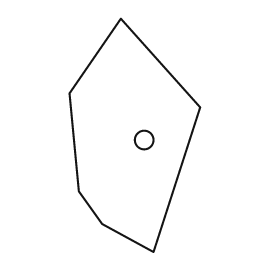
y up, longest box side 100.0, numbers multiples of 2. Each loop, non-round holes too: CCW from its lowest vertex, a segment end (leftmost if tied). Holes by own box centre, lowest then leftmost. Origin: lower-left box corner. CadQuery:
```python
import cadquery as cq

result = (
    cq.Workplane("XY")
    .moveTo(36.0, 0.0)
    .lineTo(56.0, 62.0)
    .lineTo(22.0, 100.0)
    .lineTo(0.0, 68.0)
    .lineTo(4.0, 26.0)
    .lineTo(14.0, 12.0)
    .close()
    .moveTo(32.0, 48.0)
    .circle(4.0)
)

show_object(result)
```